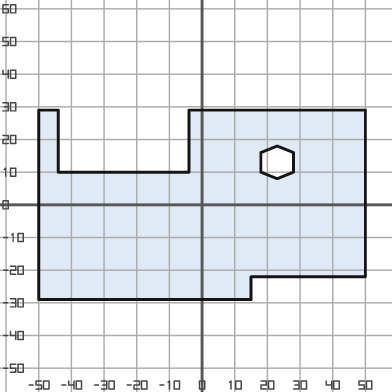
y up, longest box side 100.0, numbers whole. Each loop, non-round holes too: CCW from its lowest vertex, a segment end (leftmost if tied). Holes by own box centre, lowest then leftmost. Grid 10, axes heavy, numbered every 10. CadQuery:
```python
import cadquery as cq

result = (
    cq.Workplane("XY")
    .moveTo(-50.0, -29.0)
    .lineTo(15.0, -29.0)
    .lineTo(15.0, -22.0)
    .lineTo(50.0, -22.0)
    .lineTo(50.0, 29.0)
    .lineTo(-4.0, 29.0)
    .lineTo(-4.0, 10.0)
    .lineTo(-44.0, 10.0)
    .lineTo(-44.0, 29.0)
    .lineTo(-50.0, 29.0)
    .close()
    .moveTo(23.0, 8.0)
    .lineTo(28.0, 10.0)
    .lineTo(28.0, 16.0)
    .lineTo(23.0, 18.0)
    .lineTo(18.0, 16.0)
    .lineTo(18.0, 10.0)
    .close()
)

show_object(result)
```